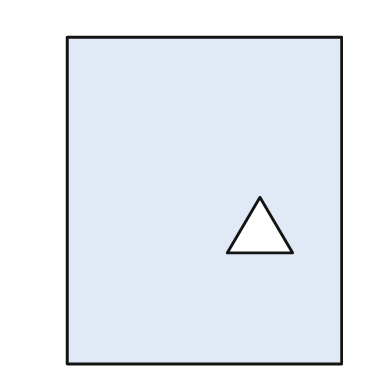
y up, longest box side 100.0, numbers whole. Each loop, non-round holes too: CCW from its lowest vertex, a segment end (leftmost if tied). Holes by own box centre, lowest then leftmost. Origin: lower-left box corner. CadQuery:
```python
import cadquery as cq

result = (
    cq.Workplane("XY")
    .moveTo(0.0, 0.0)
    .lineTo(84.0, 0.0)
    .lineTo(84.0, 100.0)
    .lineTo(0.0, 100.0)
    .close()
    .moveTo(49.0, 34.0)
    .lineTo(69.0, 34.0)
    .lineTo(59.0, 51.0)
    .close()
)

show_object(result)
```